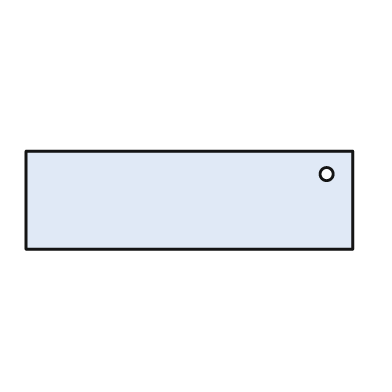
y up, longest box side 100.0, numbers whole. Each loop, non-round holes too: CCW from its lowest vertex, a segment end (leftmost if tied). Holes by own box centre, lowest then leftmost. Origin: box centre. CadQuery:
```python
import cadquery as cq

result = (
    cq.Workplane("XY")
    .moveTo(-50.0, -15.0)
    .lineTo(50.0, -15.0)
    .lineTo(50.0, 15.0)
    .lineTo(-50.0, 15.0)
    .close()
    .moveTo(42.0, 8.0)
    .circle(2.0)
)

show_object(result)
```